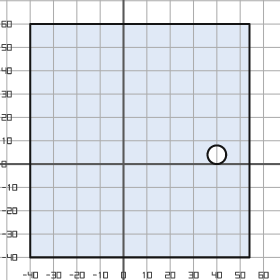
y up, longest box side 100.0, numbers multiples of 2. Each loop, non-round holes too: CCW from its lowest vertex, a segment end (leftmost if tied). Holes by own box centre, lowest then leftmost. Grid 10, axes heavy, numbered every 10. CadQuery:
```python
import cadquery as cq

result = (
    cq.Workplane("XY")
    .moveTo(-40.0, -40.0)
    .lineTo(54.0, -40.0)
    .lineTo(54.0, 60.0)
    .lineTo(-40.0, 60.0)
    .close()
    .moveTo(40.0, 4.0)
    .circle(4.0)
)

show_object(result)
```